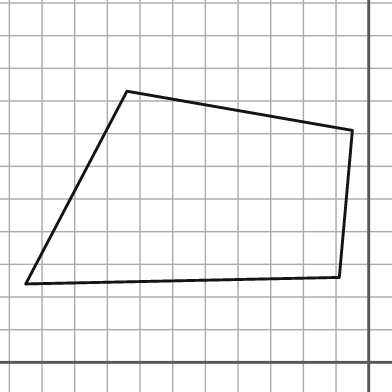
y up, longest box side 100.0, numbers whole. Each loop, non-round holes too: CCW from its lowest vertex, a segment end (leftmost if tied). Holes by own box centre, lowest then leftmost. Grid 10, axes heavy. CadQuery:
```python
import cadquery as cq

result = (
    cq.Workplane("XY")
    .moveTo(-105.0, 24.0)
    .lineTo(-9.0, 26.0)
    .lineTo(-5.0, 71.0)
    .lineTo(-74.0, 83.0)
    .close()
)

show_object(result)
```